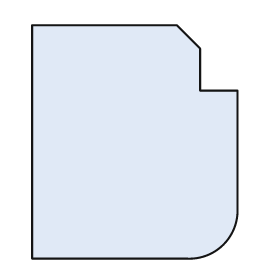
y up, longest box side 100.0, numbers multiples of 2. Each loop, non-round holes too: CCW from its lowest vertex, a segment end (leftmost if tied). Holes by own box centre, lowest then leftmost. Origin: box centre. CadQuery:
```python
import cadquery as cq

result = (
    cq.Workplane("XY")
    .moveTo(-44.0, -50.0)
    .lineTo(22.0, -50.0)
    .threePointArc((38.0, -44.0), (44.0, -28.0))
    .lineTo(44.0, 22.0)
    .lineTo(28.0, 22.0)
    .lineTo(28.0, 40.0)
    .lineTo(18.0, 50.0)
    .lineTo(-44.0, 50.0)
    .close()
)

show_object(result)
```